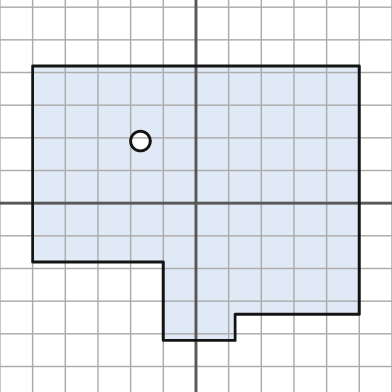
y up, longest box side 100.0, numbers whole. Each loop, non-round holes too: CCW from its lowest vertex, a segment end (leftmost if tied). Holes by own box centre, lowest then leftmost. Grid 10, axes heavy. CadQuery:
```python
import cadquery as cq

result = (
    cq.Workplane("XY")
    .moveTo(-10.0, -42.0)
    .lineTo(12.0, -42.0)
    .lineTo(12.0, -34.0)
    .lineTo(50.0, -34.0)
    .lineTo(50.0, 42.0)
    .lineTo(-50.0, 42.0)
    .lineTo(-50.0, -18.0)
    .lineTo(-10.0, -18.0)
    .close()
    .moveTo(-17.0, 19.0)
    .circle(3.0)
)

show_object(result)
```